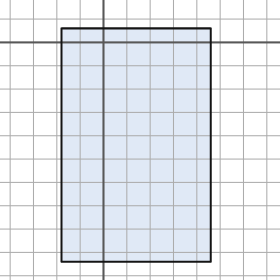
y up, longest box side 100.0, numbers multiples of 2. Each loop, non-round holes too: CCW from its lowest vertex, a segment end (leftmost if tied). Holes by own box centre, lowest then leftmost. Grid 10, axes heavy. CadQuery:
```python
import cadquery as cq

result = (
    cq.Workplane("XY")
    .moveTo(-18.0, -94.0)
    .lineTo(46.0, -94.0)
    .lineTo(46.0, 6.0)
    .lineTo(-18.0, 6.0)
    .close()
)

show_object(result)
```